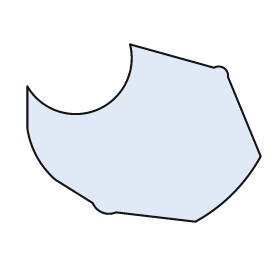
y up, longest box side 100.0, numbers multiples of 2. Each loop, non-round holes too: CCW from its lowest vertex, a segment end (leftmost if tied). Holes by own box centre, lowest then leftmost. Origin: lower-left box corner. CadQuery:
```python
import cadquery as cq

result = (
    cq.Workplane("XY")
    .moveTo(72.0, 0.0)
    .threePointArc((88.0, 12.0), (100.0, 28.0))
    .lineTo(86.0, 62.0)
    .threePointArc((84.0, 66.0), (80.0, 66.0))
    .lineTo(44.0, 76.0)
    .threePointArc((30.0, 48.0), (0.0, 58.0))
    .lineTo(0.0, 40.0)
    .threePointArc((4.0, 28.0), (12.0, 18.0))
    .lineTo(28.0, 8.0)
    .threePointArc((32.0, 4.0), (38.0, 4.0))
    .close()
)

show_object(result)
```